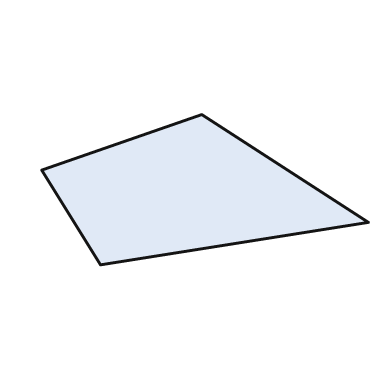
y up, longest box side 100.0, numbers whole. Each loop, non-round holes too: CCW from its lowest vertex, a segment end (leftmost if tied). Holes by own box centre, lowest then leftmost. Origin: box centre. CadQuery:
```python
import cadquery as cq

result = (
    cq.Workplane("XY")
    .moveTo(-32.0, -23.0)
    .lineTo(50.0, -10.0)
    .lineTo(-1.0, 23.0)
    .lineTo(-50.0, 6.0)
    .close()
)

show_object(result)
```